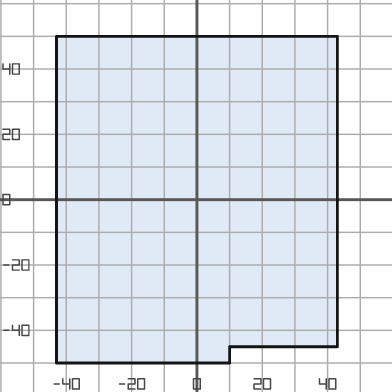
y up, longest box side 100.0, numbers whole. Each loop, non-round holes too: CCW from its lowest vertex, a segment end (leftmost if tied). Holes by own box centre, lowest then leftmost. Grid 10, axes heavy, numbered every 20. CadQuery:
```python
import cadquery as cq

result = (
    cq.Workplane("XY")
    .moveTo(-43.0, -50.0)
    .lineTo(10.0, -50.0)
    .lineTo(10.0, -45.0)
    .lineTo(43.0, -45.0)
    .lineTo(43.0, 50.0)
    .lineTo(-43.0, 50.0)
    .close()
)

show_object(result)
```